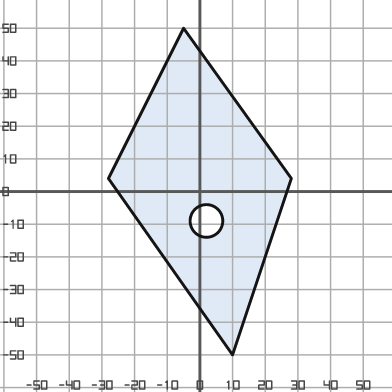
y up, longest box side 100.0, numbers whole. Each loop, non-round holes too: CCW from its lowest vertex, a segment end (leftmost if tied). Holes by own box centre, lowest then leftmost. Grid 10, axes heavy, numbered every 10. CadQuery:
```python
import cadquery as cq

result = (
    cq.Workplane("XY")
    .moveTo(10.0, -50.0)
    .lineTo(28.0, 4.0)
    .lineTo(-5.0, 50.0)
    .lineTo(-28.0, 4.0)
    .close()
    .moveTo(2.0, -9.0)
    .circle(5.0)
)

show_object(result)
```